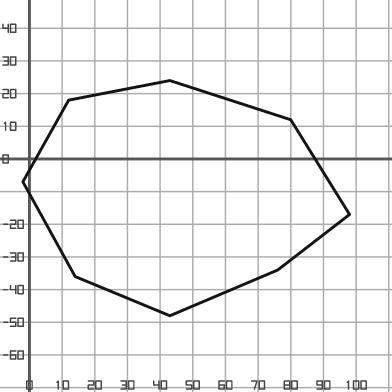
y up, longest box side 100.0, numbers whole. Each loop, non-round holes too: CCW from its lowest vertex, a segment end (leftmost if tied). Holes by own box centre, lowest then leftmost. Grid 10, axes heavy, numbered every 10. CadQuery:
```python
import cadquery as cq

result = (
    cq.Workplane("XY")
    .moveTo(43.0, -48.0)
    .lineTo(76.0, -34.0)
    .lineTo(98.0, -17.0)
    .lineTo(80.0, 12.0)
    .lineTo(43.0, 24.0)
    .lineTo(12.0, 18.0)
    .lineTo(-2.0, -7.0)
    .lineTo(14.0, -36.0)
    .close()
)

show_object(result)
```